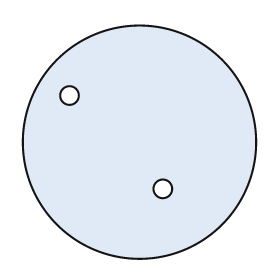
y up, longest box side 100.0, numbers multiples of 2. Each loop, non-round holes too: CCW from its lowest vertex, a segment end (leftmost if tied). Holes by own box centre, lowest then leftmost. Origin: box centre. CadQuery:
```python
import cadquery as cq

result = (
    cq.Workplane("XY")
    .moveTo(0.0, 0.0)
    .circle(50.0)
    .moveTo(10.0, -20.0)
    .circle(4.0)
    .moveTo(-30.0, 20.0)
    .circle(4.0)
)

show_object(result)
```